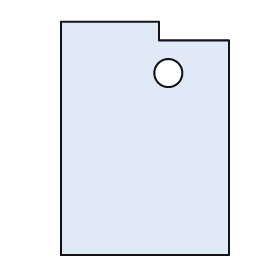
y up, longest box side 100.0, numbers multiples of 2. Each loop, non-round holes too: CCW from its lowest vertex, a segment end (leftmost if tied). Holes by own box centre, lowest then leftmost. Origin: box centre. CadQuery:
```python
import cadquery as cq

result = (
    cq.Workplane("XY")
    .moveTo(-36.0, -50.0)
    .lineTo(36.0, -50.0)
    .lineTo(36.0, 42.0)
    .lineTo(6.0, 42.0)
    .lineTo(6.0, 50.0)
    .lineTo(-36.0, 50.0)
    .close()
    .moveTo(10.0, 28.0)
    .circle(6.0)
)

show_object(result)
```